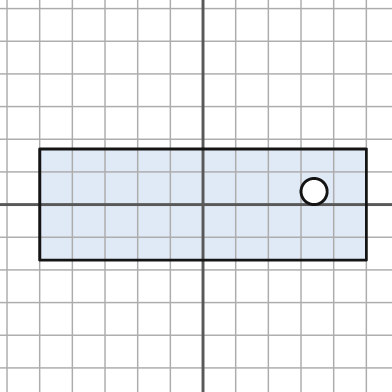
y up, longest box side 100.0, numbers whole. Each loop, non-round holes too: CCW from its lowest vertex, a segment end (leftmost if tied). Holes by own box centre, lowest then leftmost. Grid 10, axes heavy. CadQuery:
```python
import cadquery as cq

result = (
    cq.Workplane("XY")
    .moveTo(-50.0, -17.0)
    .lineTo(50.0, -17.0)
    .lineTo(50.0, 17.0)
    .lineTo(-50.0, 17.0)
    .close()
    .moveTo(34.0, 4.0)
    .circle(4.0)
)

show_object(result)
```